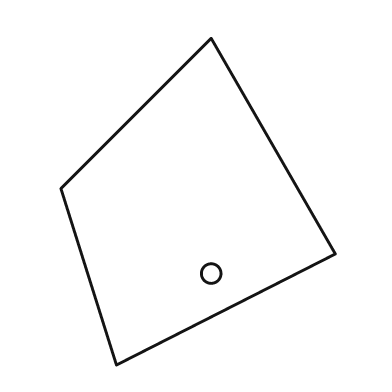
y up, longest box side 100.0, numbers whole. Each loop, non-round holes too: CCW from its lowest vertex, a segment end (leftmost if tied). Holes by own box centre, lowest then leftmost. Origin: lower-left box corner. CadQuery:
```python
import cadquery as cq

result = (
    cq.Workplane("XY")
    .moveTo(17.0, 0.0)
    .lineTo(84.0, 34.0)
    .lineTo(46.0, 100.0)
    .lineTo(0.0, 54.0)
    .close()
    .moveTo(46.0, 28.0)
    .circle(3.0)
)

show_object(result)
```